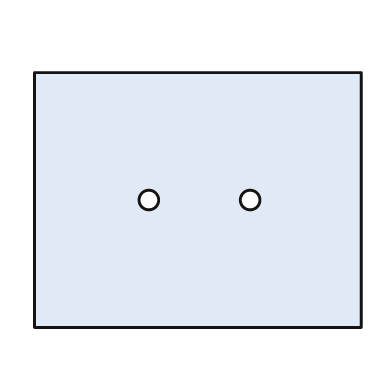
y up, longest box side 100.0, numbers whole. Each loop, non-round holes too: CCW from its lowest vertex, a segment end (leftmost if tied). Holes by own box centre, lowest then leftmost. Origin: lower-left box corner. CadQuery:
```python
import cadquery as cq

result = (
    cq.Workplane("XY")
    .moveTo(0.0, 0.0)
    .lineTo(100.0, 0.0)
    .lineTo(100.0, 78.0)
    .lineTo(0.0, 78.0)
    .close()
    .moveTo(35.0, 39.0)
    .circle(3.0)
    .moveTo(66.0, 39.0)
    .circle(3.0)
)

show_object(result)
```